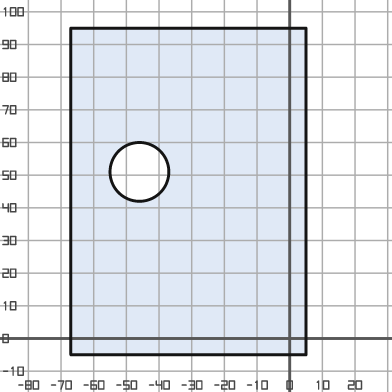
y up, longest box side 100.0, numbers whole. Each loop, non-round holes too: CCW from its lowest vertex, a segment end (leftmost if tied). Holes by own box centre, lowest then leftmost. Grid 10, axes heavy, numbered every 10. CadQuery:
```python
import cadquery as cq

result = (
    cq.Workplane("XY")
    .moveTo(-67.0, -5.0)
    .lineTo(5.0, -5.0)
    .lineTo(5.0, 95.0)
    .lineTo(-67.0, 95.0)
    .close()
    .moveTo(-46.0, 51.0)
    .circle(9.0)
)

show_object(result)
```